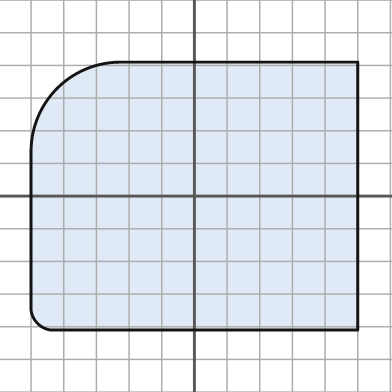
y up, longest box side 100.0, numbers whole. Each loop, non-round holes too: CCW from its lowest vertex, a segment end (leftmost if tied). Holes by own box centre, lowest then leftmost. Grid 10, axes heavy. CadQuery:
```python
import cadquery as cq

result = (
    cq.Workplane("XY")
    .moveTo(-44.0, -41.0)
    .lineTo(50.0, -41.0)
    .lineTo(50.0, 41.0)
    .lineTo(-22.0, 41.0)
    .threePointArc((-42.0, 33.0), (-50.0, 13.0))
    .lineTo(-50.0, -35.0)
    .threePointArc((-48.0, -39.0), (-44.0, -41.0))
    .close()
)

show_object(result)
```